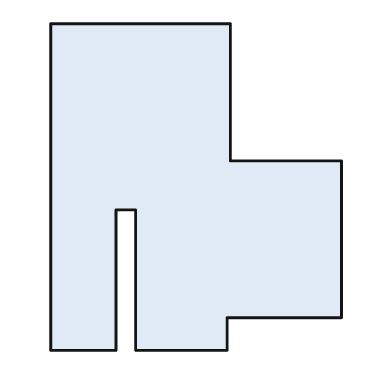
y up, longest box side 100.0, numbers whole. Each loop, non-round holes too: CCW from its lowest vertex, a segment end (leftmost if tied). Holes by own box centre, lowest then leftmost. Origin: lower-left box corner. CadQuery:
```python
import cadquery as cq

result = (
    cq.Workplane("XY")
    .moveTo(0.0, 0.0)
    .lineTo(20.0, 0.0)
    .lineTo(20.0, 43.0)
    .lineTo(26.0, 43.0)
    .lineTo(26.0, 0.0)
    .lineTo(54.0, 0.0)
    .lineTo(54.0, 10.0)
    .lineTo(89.0, 10.0)
    .lineTo(89.0, 58.0)
    .lineTo(55.0, 58.0)
    .lineTo(55.0, 100.0)
    .lineTo(0.0, 100.0)
    .close()
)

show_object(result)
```